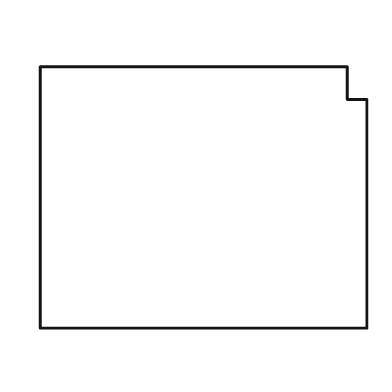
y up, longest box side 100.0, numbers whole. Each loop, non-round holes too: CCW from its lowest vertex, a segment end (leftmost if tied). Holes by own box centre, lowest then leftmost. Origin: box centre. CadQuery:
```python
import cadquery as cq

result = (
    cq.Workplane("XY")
    .moveTo(-50.0, -40.0)
    .lineTo(50.0, -40.0)
    .lineTo(50.0, 30.0)
    .lineTo(44.0, 30.0)
    .lineTo(44.0, 40.0)
    .lineTo(-50.0, 40.0)
    .close()
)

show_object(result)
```